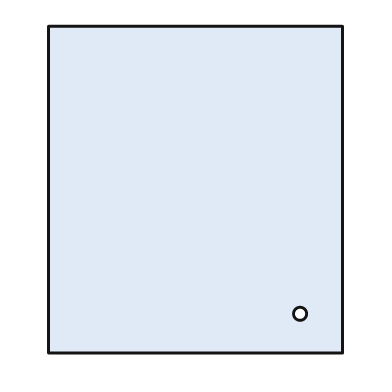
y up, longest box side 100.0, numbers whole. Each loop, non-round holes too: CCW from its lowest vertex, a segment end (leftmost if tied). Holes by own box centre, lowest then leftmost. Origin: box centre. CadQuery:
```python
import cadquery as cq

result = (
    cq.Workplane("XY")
    .moveTo(-45.0, -50.0)
    .lineTo(45.0, -50.0)
    .lineTo(45.0, 50.0)
    .lineTo(-45.0, 50.0)
    .close()
    .moveTo(32.0, -38.0)
    .circle(2.0)
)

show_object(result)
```